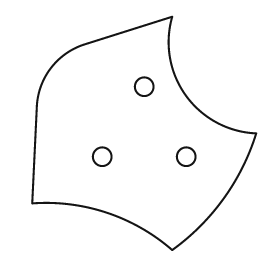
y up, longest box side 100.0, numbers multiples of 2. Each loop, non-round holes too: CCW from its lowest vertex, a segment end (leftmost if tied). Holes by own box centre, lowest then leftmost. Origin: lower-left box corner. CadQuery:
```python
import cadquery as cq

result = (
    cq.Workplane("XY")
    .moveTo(60.0, 0.0)
    .threePointArc((82.0, 22.0), (96.0, 50.0))
    .threePointArc((66.0, 66.0), (60.0, 100.0))
    .lineTo(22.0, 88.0)
    .threePointArc((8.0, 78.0), (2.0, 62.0))
    .lineTo(0.0, 20.0)
    .threePointArc((32.0, 16.0), (60.0, 0.0))
    .close()
    .moveTo(30.0, 40.0)
    .circle(4.0)
    .moveTo(66.0, 40.0)
    .circle(4.0)
    .moveTo(48.0, 70.0)
    .circle(4.0)
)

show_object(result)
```